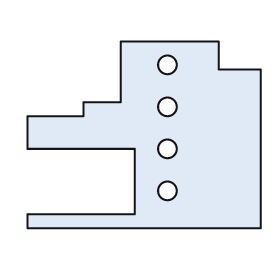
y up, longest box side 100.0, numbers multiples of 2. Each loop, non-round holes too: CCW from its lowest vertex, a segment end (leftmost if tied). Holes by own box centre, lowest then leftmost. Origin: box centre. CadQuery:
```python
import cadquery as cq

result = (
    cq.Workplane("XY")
    .moveTo(-50.0, -40.0)
    .lineTo(50.0, -40.0)
    .lineTo(50.0, 28.0)
    .lineTo(32.0, 28.0)
    .lineTo(32.0, 40.0)
    .lineTo(-10.0, 40.0)
    .lineTo(-10.0, 14.0)
    .lineTo(-26.0, 14.0)
    .lineTo(-26.0, 8.0)
    .lineTo(-50.0, 8.0)
    .lineTo(-50.0, -6.0)
    .lineTo(-4.0, -6.0)
    .lineTo(-4.0, -34.0)
    .lineTo(-50.0, -34.0)
    .close()
    .moveTo(10.0, -24.0)
    .circle(4.0)
    .moveTo(10.0, -6.0)
    .circle(4.0)
    .moveTo(10.0, 12.0)
    .circle(4.0)
    .moveTo(10.0, 30.0)
    .circle(4.0)
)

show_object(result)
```